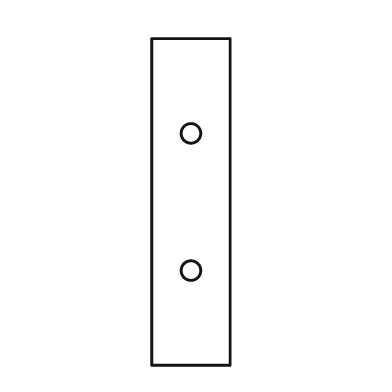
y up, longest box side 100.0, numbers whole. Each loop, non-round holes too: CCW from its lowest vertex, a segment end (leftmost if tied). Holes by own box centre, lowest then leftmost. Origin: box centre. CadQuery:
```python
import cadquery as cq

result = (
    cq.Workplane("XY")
    .moveTo(-12.0, -50.0)
    .lineTo(12.0, -50.0)
    .lineTo(12.0, 50.0)
    .lineTo(-12.0, 50.0)
    .close()
    .moveTo(0.0, -21.0)
    .circle(3.0)
    .moveTo(0.0, 21.0)
    .circle(3.0)
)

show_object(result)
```